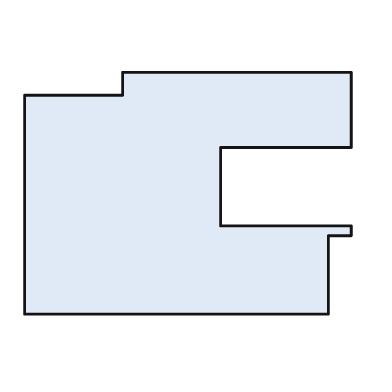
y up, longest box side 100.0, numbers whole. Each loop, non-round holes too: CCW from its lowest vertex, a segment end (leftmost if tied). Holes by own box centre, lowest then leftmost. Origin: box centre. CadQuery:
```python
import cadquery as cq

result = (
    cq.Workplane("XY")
    .moveTo(-50.0, -37.0)
    .lineTo(43.0, -37.0)
    .lineTo(43.0, -13.0)
    .lineTo(50.0, -13.0)
    .lineTo(50.0, -10.0)
    .lineTo(10.0, -10.0)
    .lineTo(10.0, 14.0)
    .lineTo(50.0, 14.0)
    .lineTo(50.0, 37.0)
    .lineTo(-20.0, 37.0)
    .lineTo(-20.0, 30.0)
    .lineTo(-50.0, 30.0)
    .close()
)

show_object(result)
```